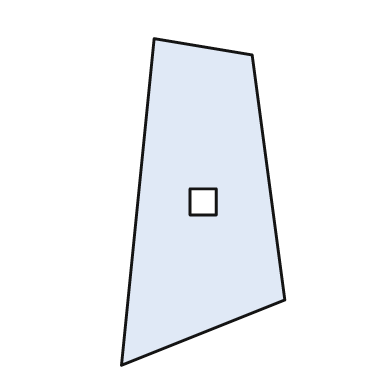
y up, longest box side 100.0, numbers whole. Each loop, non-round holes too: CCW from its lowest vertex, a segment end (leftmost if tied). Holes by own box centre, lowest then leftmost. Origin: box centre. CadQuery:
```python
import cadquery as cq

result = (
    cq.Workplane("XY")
    .moveTo(-25.0, -50.0)
    .lineTo(25.0, -30.0)
    .lineTo(15.0, 45.0)
    .lineTo(-15.0, 50.0)
    .close()
    .moveTo(-4.0, -4.0)
    .lineTo(4.0, -4.0)
    .lineTo(4.0, 4.0)
    .lineTo(-4.0, 4.0)
    .close()
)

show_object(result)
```